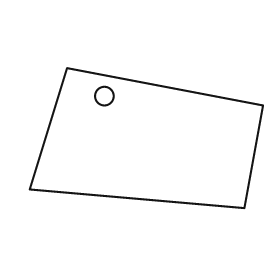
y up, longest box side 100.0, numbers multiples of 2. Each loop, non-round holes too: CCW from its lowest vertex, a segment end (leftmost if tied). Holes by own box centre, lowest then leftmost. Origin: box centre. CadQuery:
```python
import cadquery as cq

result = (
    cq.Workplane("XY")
    .moveTo(42.0, -30.0)
    .lineTo(50.0, 14.0)
    .lineTo(-34.0, 30.0)
    .lineTo(-50.0, -22.0)
    .close()
    .moveTo(-18.0, 18.0)
    .circle(4.0)
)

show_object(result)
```